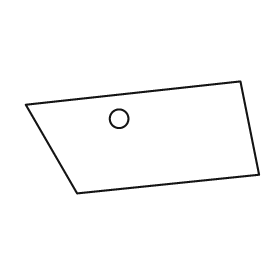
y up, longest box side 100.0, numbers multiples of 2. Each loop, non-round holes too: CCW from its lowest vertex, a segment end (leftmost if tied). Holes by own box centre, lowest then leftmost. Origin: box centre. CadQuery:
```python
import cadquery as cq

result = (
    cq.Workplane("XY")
    .moveTo(-28.0, -24.0)
    .lineTo(50.0, -16.0)
    .lineTo(42.0, 24.0)
    .lineTo(-50.0, 14.0)
    .close()
    .moveTo(-10.0, 8.0)
    .circle(4.0)
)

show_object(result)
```